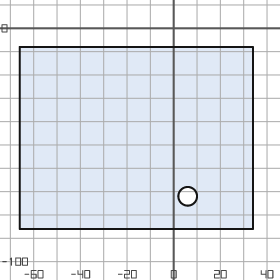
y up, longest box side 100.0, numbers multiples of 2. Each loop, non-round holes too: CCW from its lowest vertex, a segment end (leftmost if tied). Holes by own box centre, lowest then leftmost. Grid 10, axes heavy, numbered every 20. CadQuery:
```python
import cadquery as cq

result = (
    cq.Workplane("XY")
    .moveTo(-66.0, -86.0)
    .lineTo(34.0, -86.0)
    .lineTo(34.0, -8.0)
    .lineTo(-66.0, -8.0)
    .close()
    .moveTo(6.0, -72.0)
    .circle(4.0)
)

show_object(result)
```